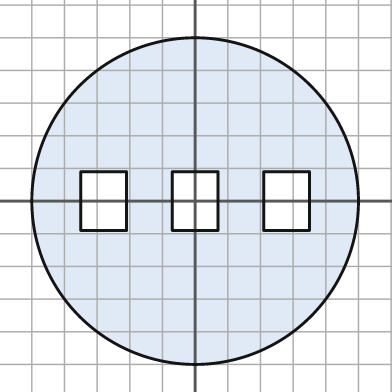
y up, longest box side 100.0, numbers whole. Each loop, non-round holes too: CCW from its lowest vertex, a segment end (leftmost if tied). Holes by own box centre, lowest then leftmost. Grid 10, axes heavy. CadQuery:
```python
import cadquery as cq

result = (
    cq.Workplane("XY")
    .moveTo(0.0, 0.0)
    .circle(50.0)
    .moveTo(-35.0, -9.0)
    .lineTo(-21.0, -9.0)
    .lineTo(-21.0, 9.0)
    .lineTo(-35.0, 9.0)
    .close()
    .moveTo(-7.0, -9.0)
    .lineTo(7.0, -9.0)
    .lineTo(7.0, 9.0)
    .lineTo(-7.0, 9.0)
    .close()
    .moveTo(21.0, -9.0)
    .lineTo(35.0, -9.0)
    .lineTo(35.0, 9.0)
    .lineTo(21.0, 9.0)
    .close()
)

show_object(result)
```